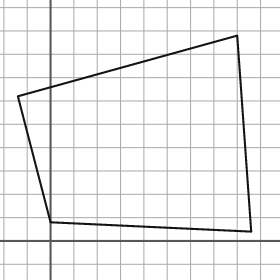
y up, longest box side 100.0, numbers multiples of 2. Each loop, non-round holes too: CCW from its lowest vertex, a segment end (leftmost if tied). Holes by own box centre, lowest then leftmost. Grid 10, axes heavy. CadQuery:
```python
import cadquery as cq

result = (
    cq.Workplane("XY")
    .moveTo(86.0, 4.0)
    .lineTo(80.0, 88.0)
    .lineTo(-14.0, 62.0)
    .lineTo(0.0, 8.0)
    .close()
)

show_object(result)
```